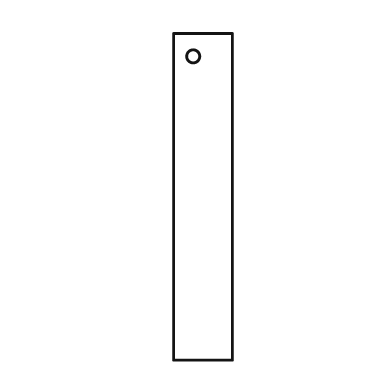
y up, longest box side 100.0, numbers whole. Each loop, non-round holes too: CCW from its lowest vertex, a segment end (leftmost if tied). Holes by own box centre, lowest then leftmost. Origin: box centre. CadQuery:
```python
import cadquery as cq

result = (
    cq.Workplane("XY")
    .moveTo(-9.0, -50.0)
    .lineTo(9.0, -50.0)
    .lineTo(9.0, 50.0)
    .lineTo(-9.0, 50.0)
    .close()
    .moveTo(-3.0, 43.0)
    .circle(2.0)
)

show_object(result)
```